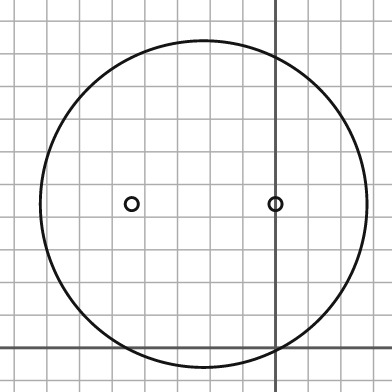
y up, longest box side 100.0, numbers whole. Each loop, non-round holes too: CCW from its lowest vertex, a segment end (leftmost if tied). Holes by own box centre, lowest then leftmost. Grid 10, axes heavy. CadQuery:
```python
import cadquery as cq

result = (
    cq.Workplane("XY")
    .moveTo(-22.0, 44.0)
    .circle(50.0)
    .moveTo(-44.0, 44.0)
    .circle(2.0)
    .moveTo(0.0, 44.0)
    .circle(2.0)
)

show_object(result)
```